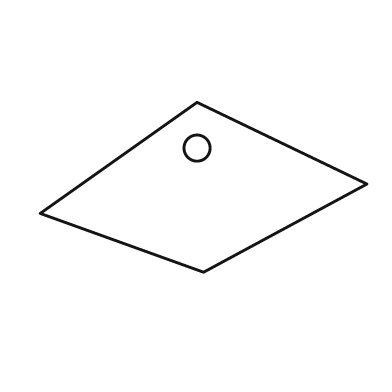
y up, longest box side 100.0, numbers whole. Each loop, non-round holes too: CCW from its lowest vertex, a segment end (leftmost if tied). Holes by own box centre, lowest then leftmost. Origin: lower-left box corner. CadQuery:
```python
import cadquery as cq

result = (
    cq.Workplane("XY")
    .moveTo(50.0, 0.0)
    .lineTo(100.0, 27.0)
    .lineTo(48.0, 52.0)
    .lineTo(0.0, 18.0)
    .close()
    .moveTo(48.0, 38.0)
    .circle(4.0)
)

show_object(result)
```